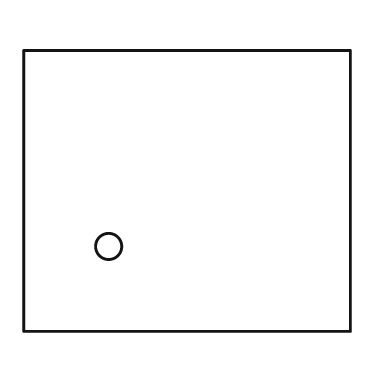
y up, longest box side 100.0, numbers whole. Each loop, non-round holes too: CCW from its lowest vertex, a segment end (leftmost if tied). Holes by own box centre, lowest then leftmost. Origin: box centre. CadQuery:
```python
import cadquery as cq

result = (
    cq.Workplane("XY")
    .moveTo(-50.0, -43.0)
    .lineTo(50.0, -43.0)
    .lineTo(50.0, 43.0)
    .lineTo(-50.0, 43.0)
    .close()
    .moveTo(-24.0, -17.0)
    .circle(4.0)
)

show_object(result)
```